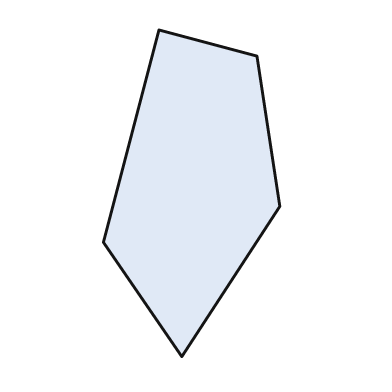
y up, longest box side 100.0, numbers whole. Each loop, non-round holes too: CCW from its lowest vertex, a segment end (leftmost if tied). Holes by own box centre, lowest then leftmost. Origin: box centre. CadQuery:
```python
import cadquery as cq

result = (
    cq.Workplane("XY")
    .moveTo(-3.0, -50.0)
    .lineTo(27.0, -4.0)
    .lineTo(20.0, 42.0)
    .lineTo(-10.0, 50.0)
    .lineTo(-27.0, -15.0)
    .close()
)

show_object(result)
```